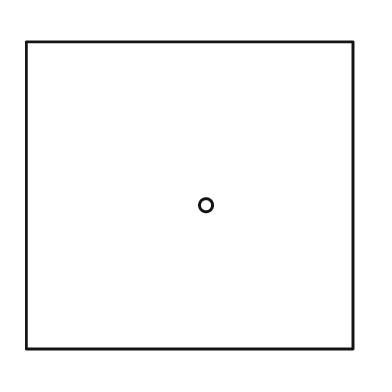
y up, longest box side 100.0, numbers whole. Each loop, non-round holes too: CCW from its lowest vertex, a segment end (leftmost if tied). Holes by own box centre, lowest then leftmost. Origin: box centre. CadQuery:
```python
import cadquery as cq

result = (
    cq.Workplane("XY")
    .moveTo(-50.0, -47.0)
    .lineTo(50.0, -47.0)
    .lineTo(50.0, 47.0)
    .lineTo(-50.0, 47.0)
    .close()
    .moveTo(5.0, -3.0)
    .circle(2.0)
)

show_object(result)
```